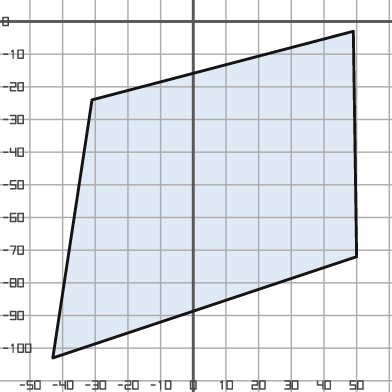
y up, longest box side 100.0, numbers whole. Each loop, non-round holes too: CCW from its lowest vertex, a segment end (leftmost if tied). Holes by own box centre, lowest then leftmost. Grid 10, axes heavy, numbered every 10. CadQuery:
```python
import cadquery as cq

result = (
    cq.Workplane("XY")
    .moveTo(-43.0, -103.0)
    .lineTo(50.0, -72.0)
    .lineTo(49.0, -3.0)
    .lineTo(-31.0, -24.0)
    .close()
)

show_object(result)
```